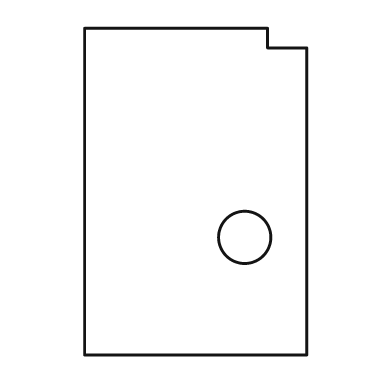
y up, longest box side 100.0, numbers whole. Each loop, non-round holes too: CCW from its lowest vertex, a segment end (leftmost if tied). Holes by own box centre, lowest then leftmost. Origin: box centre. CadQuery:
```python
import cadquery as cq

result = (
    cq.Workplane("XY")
    .moveTo(-34.0, -50.0)
    .lineTo(34.0, -50.0)
    .lineTo(34.0, 44.0)
    .lineTo(22.0, 44.0)
    .lineTo(22.0, 50.0)
    .lineTo(-34.0, 50.0)
    .close()
    .moveTo(15.0, -14.0)
    .circle(8.0)
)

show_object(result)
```